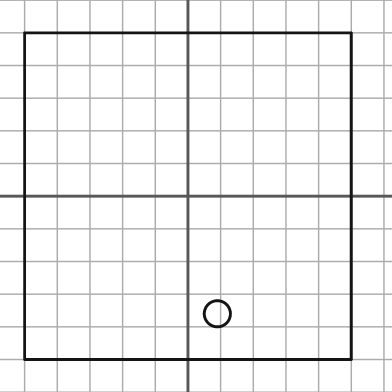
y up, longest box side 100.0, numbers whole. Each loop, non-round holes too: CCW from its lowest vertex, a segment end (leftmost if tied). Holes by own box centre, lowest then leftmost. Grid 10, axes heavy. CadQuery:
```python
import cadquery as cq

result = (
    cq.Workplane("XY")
    .moveTo(-50.0, -50.0)
    .lineTo(50.0, -50.0)
    .lineTo(50.0, 50.0)
    .lineTo(-50.0, 50.0)
    .close()
    .moveTo(9.0, -36.0)
    .circle(4.0)
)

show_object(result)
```